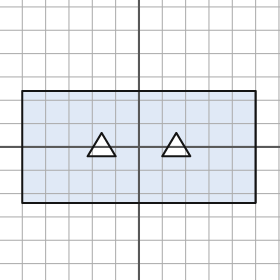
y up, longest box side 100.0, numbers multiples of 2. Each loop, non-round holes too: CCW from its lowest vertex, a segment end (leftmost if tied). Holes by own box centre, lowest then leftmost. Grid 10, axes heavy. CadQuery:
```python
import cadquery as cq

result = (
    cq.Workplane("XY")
    .moveTo(-50.0, -24.0)
    .lineTo(50.0, -24.0)
    .lineTo(50.0, 24.0)
    .lineTo(-50.0, 24.0)
    .close()
    .moveTo(-22.0, -4.0)
    .lineTo(-10.0, -4.0)
    .lineTo(-16.0, 6.0)
    .close()
    .moveTo(10.0, -4.0)
    .lineTo(22.0, -4.0)
    .lineTo(16.0, 6.0)
    .close()
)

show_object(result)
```